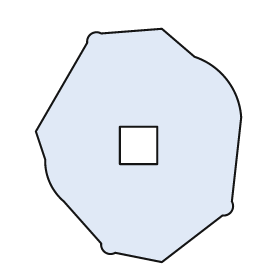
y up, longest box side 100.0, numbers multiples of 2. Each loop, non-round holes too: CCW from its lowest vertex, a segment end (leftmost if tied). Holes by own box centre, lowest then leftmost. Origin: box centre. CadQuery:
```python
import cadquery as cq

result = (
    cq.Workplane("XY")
    .moveTo(10.0, -50.0)
    .lineTo(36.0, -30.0)
    .threePointArc((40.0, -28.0), (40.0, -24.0))
    .lineTo(44.0, 12.0)
    .threePointArc((38.0, 28.0), (24.0, 38.0))
    .lineTo(10.0, 50.0)
    .lineTo(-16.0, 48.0)
    .threePointArc((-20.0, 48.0), (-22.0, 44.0))
    .lineTo(-44.0, 6.0)
    .lineTo(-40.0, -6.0)
    .threePointArc((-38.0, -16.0), (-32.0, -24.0))
    .lineTo(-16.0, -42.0)
    .threePointArc((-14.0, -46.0), (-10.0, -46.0))
    .close()
    .moveTo(-8.0, -8.0)
    .lineTo(8.0, -8.0)
    .lineTo(8.0, 8.0)
    .lineTo(-8.0, 8.0)
    .close()
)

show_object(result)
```